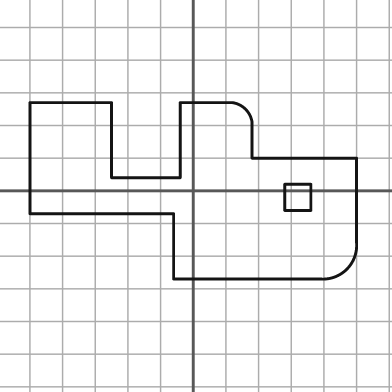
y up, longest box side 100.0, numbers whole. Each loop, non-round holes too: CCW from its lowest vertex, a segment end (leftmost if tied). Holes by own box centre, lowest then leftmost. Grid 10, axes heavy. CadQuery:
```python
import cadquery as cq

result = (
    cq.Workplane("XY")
    .moveTo(-6.0, -27.0)
    .lineTo(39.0, -27.0)
    .threePointArc((47.0, -24.0), (50.0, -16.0))
    .lineTo(50.0, 10.0)
    .lineTo(18.0, 10.0)
    .lineTo(18.0, 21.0)
    .threePointArc((16.0, 25.0), (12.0, 27.0))
    .lineTo(-4.0, 27.0)
    .lineTo(-4.0, 4.0)
    .lineTo(-25.0, 4.0)
    .lineTo(-25.0, 27.0)
    .lineTo(-50.0, 27.0)
    .lineTo(-50.0, -7.0)
    .lineTo(-6.0, -7.0)
    .close()
    .moveTo(28.0, -6.0)
    .lineTo(36.0, -6.0)
    .lineTo(36.0, 2.0)
    .lineTo(28.0, 2.0)
    .close()
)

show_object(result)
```